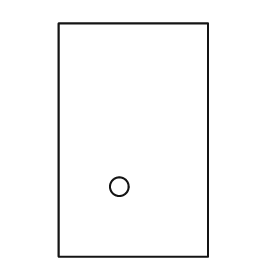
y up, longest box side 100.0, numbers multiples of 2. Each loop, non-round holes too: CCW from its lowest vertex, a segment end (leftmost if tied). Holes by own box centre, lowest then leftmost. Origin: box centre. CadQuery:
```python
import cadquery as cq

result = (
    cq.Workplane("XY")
    .moveTo(-32.0, -50.0)
    .lineTo(32.0, -50.0)
    .lineTo(32.0, 50.0)
    .lineTo(-32.0, 50.0)
    .close()
    .moveTo(-6.0, -20.0)
    .circle(4.0)
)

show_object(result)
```